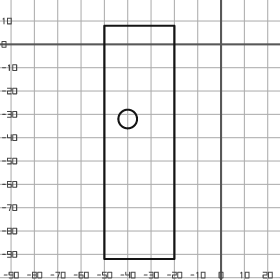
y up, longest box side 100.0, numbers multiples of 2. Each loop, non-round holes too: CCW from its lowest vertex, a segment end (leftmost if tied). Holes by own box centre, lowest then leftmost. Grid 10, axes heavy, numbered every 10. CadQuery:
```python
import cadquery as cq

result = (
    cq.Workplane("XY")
    .moveTo(-50.0, -92.0)
    .lineTo(-20.0, -92.0)
    .lineTo(-20.0, 8.0)
    .lineTo(-50.0, 8.0)
    .close()
    .moveTo(-40.0, -32.0)
    .circle(4.0)
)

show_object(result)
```